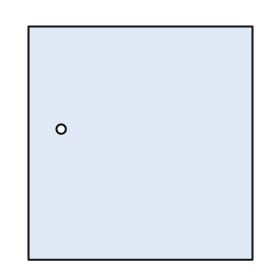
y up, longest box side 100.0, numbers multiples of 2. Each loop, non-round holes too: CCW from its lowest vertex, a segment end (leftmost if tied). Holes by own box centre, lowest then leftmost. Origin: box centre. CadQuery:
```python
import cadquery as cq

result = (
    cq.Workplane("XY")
    .moveTo(-48.0, -50.0)
    .lineTo(48.0, -50.0)
    .lineTo(48.0, 50.0)
    .lineTo(-48.0, 50.0)
    .close()
    .moveTo(-34.0, 6.0)
    .circle(2.0)
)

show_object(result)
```